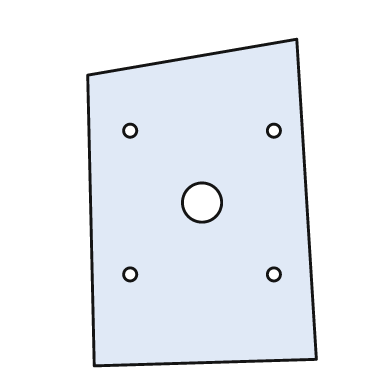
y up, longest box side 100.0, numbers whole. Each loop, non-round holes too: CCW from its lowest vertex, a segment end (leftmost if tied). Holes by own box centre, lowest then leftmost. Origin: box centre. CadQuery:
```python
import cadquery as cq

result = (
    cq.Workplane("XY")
    .moveTo(-33.0, -50.0)
    .lineTo(35.0, -48.0)
    .lineTo(29.0, 50.0)
    .lineTo(-35.0, 39.0)
    .close()
    .moveTo(-22.0, -22.0)
    .circle(2.0)
    .moveTo(22.0, -22.0)
    .circle(2.0)
    .moveTo(0.0, 0.0)
    .circle(6.0)
    .moveTo(-22.0, 22.0)
    .circle(2.0)
    .moveTo(22.0, 22.0)
    .circle(2.0)
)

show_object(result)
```